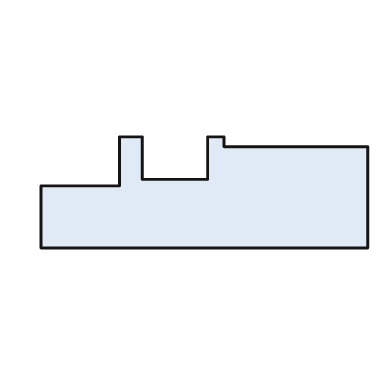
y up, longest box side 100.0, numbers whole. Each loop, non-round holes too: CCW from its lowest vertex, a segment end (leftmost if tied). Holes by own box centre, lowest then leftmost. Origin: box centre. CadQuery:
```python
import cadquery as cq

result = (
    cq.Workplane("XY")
    .moveTo(-50.0, -17.0)
    .lineTo(50.0, -17.0)
    .lineTo(50.0, 14.0)
    .lineTo(6.0, 14.0)
    .lineTo(6.0, 17.0)
    .lineTo(1.0, 17.0)
    .lineTo(1.0, 4.0)
    .lineTo(-19.0, 4.0)
    .lineTo(-19.0, 17.0)
    .lineTo(-26.0, 17.0)
    .lineTo(-26.0, 2.0)
    .lineTo(-50.0, 2.0)
    .close()
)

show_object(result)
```